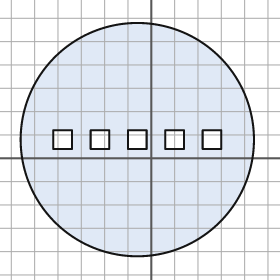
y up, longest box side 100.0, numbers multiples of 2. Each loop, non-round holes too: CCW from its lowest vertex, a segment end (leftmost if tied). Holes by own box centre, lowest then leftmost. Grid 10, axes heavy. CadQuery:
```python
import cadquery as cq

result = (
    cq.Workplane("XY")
    .moveTo(-6.0, 8.0)
    .circle(50.0)
    .moveTo(-42.0, 4.0)
    .lineTo(-34.0, 4.0)
    .lineTo(-34.0, 12.0)
    .lineTo(-42.0, 12.0)
    .close()
    .moveTo(-26.0, 4.0)
    .lineTo(-18.0, 4.0)
    .lineTo(-18.0, 12.0)
    .lineTo(-26.0, 12.0)
    .close()
    .moveTo(-10.0, 4.0)
    .lineTo(-2.0, 4.0)
    .lineTo(-2.0, 12.0)
    .lineTo(-10.0, 12.0)
    .close()
    .moveTo(6.0, 4.0)
    .lineTo(14.0, 4.0)
    .lineTo(14.0, 12.0)
    .lineTo(6.0, 12.0)
    .close()
    .moveTo(22.0, 4.0)
    .lineTo(30.0, 4.0)
    .lineTo(30.0, 12.0)
    .lineTo(22.0, 12.0)
    .close()
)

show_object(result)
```